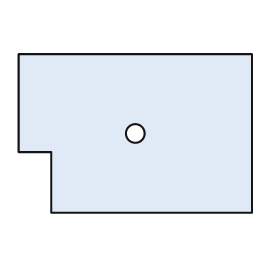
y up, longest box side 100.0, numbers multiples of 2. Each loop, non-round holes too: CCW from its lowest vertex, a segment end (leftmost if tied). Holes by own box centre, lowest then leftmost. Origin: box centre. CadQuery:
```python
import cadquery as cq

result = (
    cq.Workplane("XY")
    .moveTo(-36.0, -34.0)
    .lineTo(50.0, -34.0)
    .lineTo(50.0, 34.0)
    .lineTo(-50.0, 34.0)
    .lineTo(-50.0, -8.0)
    .lineTo(-36.0, -8.0)
    .close()
    .moveTo(0.0, 0.0)
    .circle(4.0)
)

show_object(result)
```